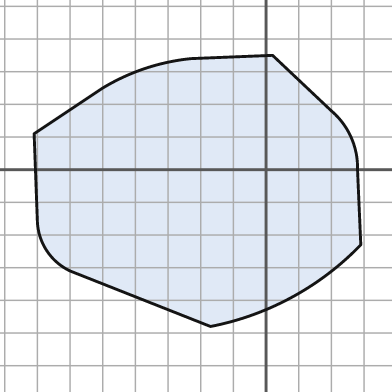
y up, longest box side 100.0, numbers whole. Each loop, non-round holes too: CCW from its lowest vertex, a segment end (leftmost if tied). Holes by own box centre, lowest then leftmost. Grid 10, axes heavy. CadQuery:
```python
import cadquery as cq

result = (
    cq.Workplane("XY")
    .moveTo(-17.0, -48.0)
    .threePointArc((8.0, -39.0), (29.0, -23.0))
    .lineTo(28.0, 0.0)
    .threePointArc((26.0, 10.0), (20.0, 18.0))
    .lineTo(2.0, 35.0)
    .lineTo(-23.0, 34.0)
    .threePointArc((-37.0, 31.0), (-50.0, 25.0))
    .lineTo(-71.0, 11.0)
    .lineTo(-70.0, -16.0)
    .threePointArc((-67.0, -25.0), (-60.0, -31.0))
    .close()
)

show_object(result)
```